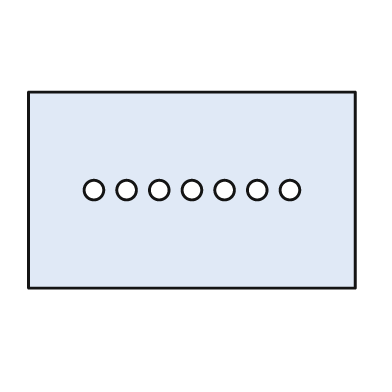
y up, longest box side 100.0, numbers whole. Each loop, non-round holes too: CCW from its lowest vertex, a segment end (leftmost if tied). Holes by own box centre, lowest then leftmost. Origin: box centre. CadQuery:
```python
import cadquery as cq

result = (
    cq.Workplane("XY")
    .moveTo(-50.0, -30.0)
    .lineTo(50.0, -30.0)
    .lineTo(50.0, 30.0)
    .lineTo(-50.0, 30.0)
    .close()
    .moveTo(-30.0, 0.0)
    .circle(3.0)
    .moveTo(-20.0, 0.0)
    .circle(3.0)
    .moveTo(-10.0, 0.0)
    .circle(3.0)
    .moveTo(0.0, 0.0)
    .circle(3.0)
    .moveTo(10.0, 0.0)
    .circle(3.0)
    .moveTo(20.0, 0.0)
    .circle(3.0)
    .moveTo(30.0, 0.0)
    .circle(3.0)
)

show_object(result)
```